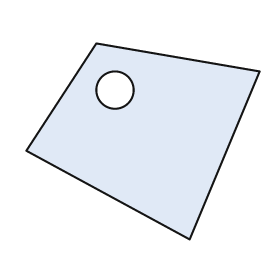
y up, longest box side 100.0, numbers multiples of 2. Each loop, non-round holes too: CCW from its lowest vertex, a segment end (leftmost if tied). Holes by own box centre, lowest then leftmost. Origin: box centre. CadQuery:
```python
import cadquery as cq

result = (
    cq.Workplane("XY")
    .moveTo(20.0, -42.0)
    .lineTo(50.0, 30.0)
    .lineTo(-20.0, 42.0)
    .lineTo(-50.0, -4.0)
    .close()
    .moveTo(-12.0, 22.0)
    .circle(8.0)
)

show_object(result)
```